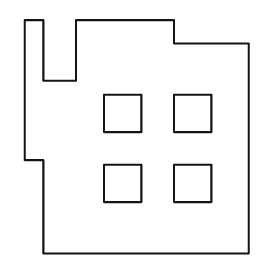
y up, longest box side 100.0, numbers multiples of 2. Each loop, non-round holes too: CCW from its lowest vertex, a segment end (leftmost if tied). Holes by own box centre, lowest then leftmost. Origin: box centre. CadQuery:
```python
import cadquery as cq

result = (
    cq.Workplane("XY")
    .moveTo(-40.0, -50.0)
    .lineTo(48.0, -50.0)
    .lineTo(48.0, 40.0)
    .lineTo(16.0, 40.0)
    .lineTo(16.0, 50.0)
    .lineTo(-26.0, 50.0)
    .lineTo(-26.0, 24.0)
    .lineTo(-40.0, 24.0)
    .lineTo(-40.0, 50.0)
    .lineTo(-48.0, 50.0)
    .lineTo(-48.0, -10.0)
    .lineTo(-40.0, -10.0)
    .close()
    .moveTo(-14.0, -28.0)
    .lineTo(2.0, -28.0)
    .lineTo(2.0, -12.0)
    .lineTo(-14.0, -12.0)
    .close()
    .moveTo(16.0, -28.0)
    .lineTo(32.0, -28.0)
    .lineTo(32.0, -12.0)
    .lineTo(16.0, -12.0)
    .close()
    .moveTo(-14.0, 2.0)
    .lineTo(2.0, 2.0)
    .lineTo(2.0, 18.0)
    .lineTo(-14.0, 18.0)
    .close()
    .moveTo(16.0, 2.0)
    .lineTo(32.0, 2.0)
    .lineTo(32.0, 18.0)
    .lineTo(16.0, 18.0)
    .close()
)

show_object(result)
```